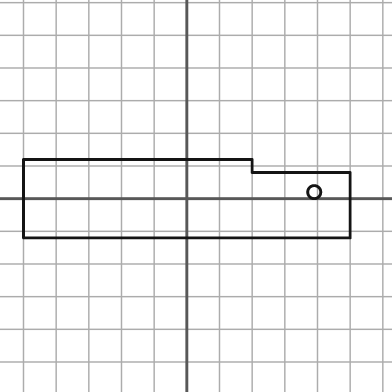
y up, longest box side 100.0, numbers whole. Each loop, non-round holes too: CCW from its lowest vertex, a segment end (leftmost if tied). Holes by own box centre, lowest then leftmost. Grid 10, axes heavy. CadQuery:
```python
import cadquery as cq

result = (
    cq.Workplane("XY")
    .moveTo(-50.0, -12.0)
    .lineTo(50.0, -12.0)
    .lineTo(50.0, 8.0)
    .lineTo(20.0, 8.0)
    .lineTo(20.0, 12.0)
    .lineTo(-50.0, 12.0)
    .close()
    .moveTo(39.0, 2.0)
    .circle(2.0)
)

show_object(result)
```